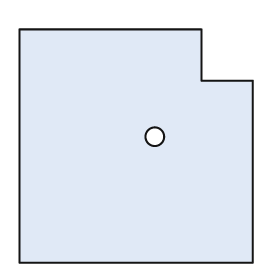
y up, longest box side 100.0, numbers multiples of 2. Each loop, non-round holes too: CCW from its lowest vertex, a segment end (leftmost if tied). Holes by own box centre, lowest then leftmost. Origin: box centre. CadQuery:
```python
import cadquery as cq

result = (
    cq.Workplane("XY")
    .moveTo(-50.0, -50.0)
    .lineTo(50.0, -50.0)
    .lineTo(50.0, 28.0)
    .lineTo(28.0, 28.0)
    .lineTo(28.0, 50.0)
    .lineTo(-50.0, 50.0)
    .close()
    .moveTo(8.0, 4.0)
    .circle(4.0)
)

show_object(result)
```